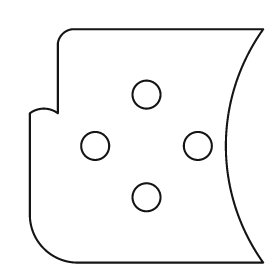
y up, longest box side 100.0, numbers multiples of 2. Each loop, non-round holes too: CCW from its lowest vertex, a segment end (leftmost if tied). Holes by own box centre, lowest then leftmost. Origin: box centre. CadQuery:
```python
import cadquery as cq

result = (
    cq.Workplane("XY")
    .moveTo(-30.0, -50.0)
    .lineTo(50.0, -50.0)
    .threePointArc((34.0, 0.0), (50.0, 50.0))
    .lineTo(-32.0, 50.0)
    .threePointArc((-36.0, 48.0), (-38.0, 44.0))
    .lineTo(-38.0, 14.0)
    .threePointArc((-44.0, 16.0), (-50.0, 14.0))
    .lineTo(-50.0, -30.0)
    .threePointArc((-44.0, -44.0), (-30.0, -50.0))
    .close()
    .moveTo(0.0, -22.0)
    .circle(6.0)
    .moveTo(-22.0, 0.0)
    .circle(6.0)
    .moveTo(22.0, 0.0)
    .circle(6.0)
    .moveTo(0.0, 22.0)
    .circle(6.0)
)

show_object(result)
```